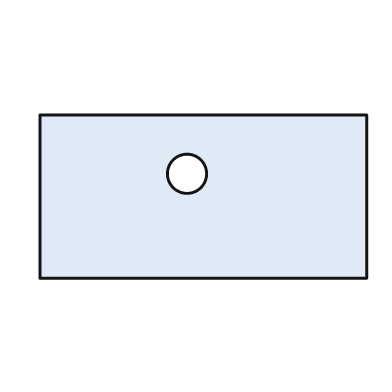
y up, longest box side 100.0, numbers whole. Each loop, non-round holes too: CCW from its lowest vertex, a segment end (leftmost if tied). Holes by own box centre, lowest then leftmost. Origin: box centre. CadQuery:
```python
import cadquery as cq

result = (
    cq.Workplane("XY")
    .moveTo(-50.0, -25.0)
    .lineTo(50.0, -25.0)
    .lineTo(50.0, 25.0)
    .lineTo(-50.0, 25.0)
    .close()
    .moveTo(-5.0, 7.0)
    .circle(6.0)
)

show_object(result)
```